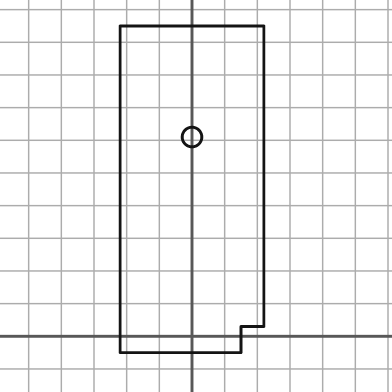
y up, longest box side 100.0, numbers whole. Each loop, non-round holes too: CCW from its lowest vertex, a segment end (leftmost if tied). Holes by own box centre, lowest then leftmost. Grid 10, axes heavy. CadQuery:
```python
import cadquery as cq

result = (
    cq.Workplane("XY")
    .moveTo(-22.0, -5.0)
    .lineTo(15.0, -5.0)
    .lineTo(15.0, 3.0)
    .lineTo(22.0, 3.0)
    .lineTo(22.0, 95.0)
    .lineTo(-22.0, 95.0)
    .close()
    .moveTo(0.0, 61.0)
    .circle(3.0)
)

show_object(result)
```